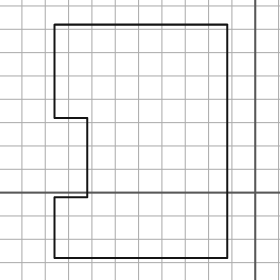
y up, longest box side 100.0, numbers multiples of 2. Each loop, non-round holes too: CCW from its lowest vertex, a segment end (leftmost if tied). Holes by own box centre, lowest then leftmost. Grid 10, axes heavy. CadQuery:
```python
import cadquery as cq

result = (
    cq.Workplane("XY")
    .moveTo(-86.0, -28.0)
    .lineTo(-12.0, -28.0)
    .lineTo(-12.0, 72.0)
    .lineTo(-86.0, 72.0)
    .lineTo(-86.0, 32.0)
    .lineTo(-72.0, 32.0)
    .lineTo(-72.0, -2.0)
    .lineTo(-86.0, -2.0)
    .close()
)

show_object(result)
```